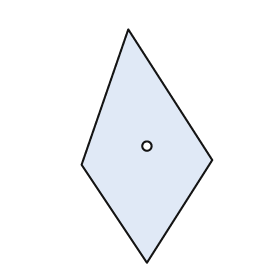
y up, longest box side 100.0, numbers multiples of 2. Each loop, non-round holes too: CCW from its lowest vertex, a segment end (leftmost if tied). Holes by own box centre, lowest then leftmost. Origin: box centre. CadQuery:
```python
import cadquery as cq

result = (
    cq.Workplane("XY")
    .moveTo(0.0, -50.0)
    .lineTo(28.0, -6.0)
    .lineTo(-8.0, 50.0)
    .lineTo(-28.0, -8.0)
    .close()
    .moveTo(0.0, 0.0)
    .circle(2.0)
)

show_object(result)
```